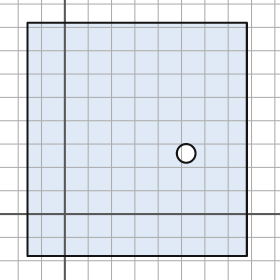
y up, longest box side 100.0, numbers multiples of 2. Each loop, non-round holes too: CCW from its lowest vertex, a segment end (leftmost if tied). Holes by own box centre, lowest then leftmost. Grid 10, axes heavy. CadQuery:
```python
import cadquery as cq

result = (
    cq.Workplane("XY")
    .moveTo(-16.0, -18.0)
    .lineTo(78.0, -18.0)
    .lineTo(78.0, 82.0)
    .lineTo(-16.0, 82.0)
    .close()
    .moveTo(52.0, 26.0)
    .circle(4.0)
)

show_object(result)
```